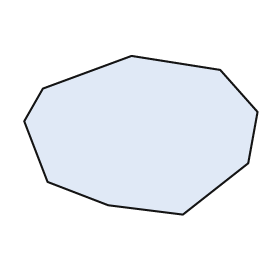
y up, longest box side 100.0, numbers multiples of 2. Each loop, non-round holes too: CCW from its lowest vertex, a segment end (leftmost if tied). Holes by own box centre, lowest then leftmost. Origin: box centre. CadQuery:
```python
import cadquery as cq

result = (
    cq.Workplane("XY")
    .moveTo(18.0, -34.0)
    .lineTo(46.0, -12.0)
    .lineTo(50.0, 10.0)
    .lineTo(34.0, 28.0)
    .lineTo(-4.0, 34.0)
    .lineTo(-42.0, 20.0)
    .lineTo(-50.0, 6.0)
    .lineTo(-40.0, -20.0)
    .lineTo(-14.0, -30.0)
    .close()
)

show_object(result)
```